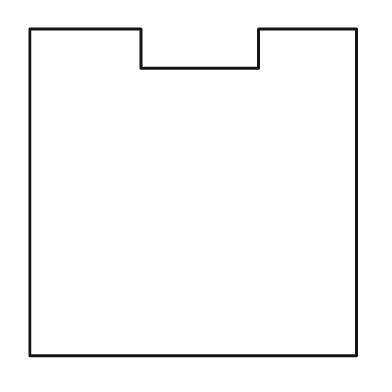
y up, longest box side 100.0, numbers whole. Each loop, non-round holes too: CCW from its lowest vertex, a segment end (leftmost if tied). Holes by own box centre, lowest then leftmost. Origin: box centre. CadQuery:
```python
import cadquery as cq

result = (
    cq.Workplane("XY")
    .moveTo(-50.0, -50.0)
    .lineTo(50.0, -50.0)
    .lineTo(50.0, 50.0)
    .lineTo(20.0, 50.0)
    .lineTo(20.0, 38.0)
    .lineTo(-16.0, 38.0)
    .lineTo(-16.0, 50.0)
    .lineTo(-50.0, 50.0)
    .close()
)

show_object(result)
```